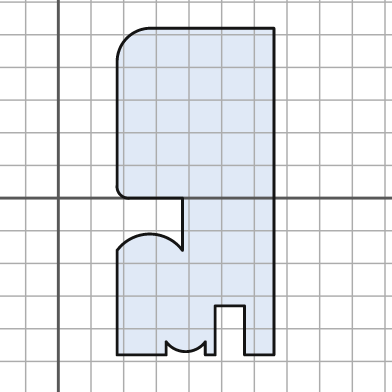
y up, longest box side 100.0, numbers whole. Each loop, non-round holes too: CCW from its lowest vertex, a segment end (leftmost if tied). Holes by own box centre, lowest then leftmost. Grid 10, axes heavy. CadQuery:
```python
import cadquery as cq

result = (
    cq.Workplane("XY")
    .moveTo(18.0, -48.0)
    .lineTo(33.0, -48.0)
    .lineTo(33.0, -44.0)
    .threePointArc((39.0, -47.0), (45.0, -44.0))
    .lineTo(45.0, -48.0)
    .lineTo(48.0, -48.0)
    .lineTo(48.0, -33.0)
    .lineTo(57.0, -33.0)
    .lineTo(57.0, -48.0)
    .lineTo(66.0, -48.0)
    .lineTo(66.0, 52.0)
    .lineTo(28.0, 52.0)
    .threePointArc((21.0, 49.0), (18.0, 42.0))
    .lineTo(18.0, 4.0)
    .threePointArc((19.0, 1.0), (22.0, 0.0))
    .lineTo(38.0, 0.0)
    .lineTo(38.0, -16.0)
    .threePointArc((28.0, -11.0), (18.0, -16.0))
    .close()
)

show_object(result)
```